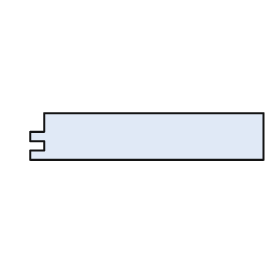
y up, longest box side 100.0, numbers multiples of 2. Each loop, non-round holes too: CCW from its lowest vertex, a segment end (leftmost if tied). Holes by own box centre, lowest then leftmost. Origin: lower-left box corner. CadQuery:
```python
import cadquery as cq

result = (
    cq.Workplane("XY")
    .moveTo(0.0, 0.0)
    .lineTo(100.0, 0.0)
    .lineTo(100.0, 20.0)
    .lineTo(6.0, 20.0)
    .lineTo(6.0, 12.0)
    .lineTo(0.0, 12.0)
    .lineTo(0.0, 8.0)
    .lineTo(6.0, 8.0)
    .lineTo(6.0, 4.0)
    .lineTo(0.0, 4.0)
    .close()
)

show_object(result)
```